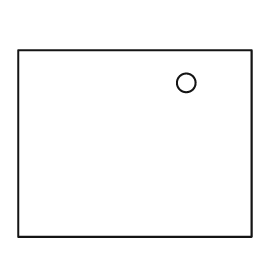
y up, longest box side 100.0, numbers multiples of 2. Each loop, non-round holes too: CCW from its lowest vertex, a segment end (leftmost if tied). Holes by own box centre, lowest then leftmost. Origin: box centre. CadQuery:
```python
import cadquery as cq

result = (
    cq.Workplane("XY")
    .moveTo(-50.0, -40.0)
    .lineTo(50.0, -40.0)
    .lineTo(50.0, 40.0)
    .lineTo(-50.0, 40.0)
    .close()
    .moveTo(22.0, 26.0)
    .circle(4.0)
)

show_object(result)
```